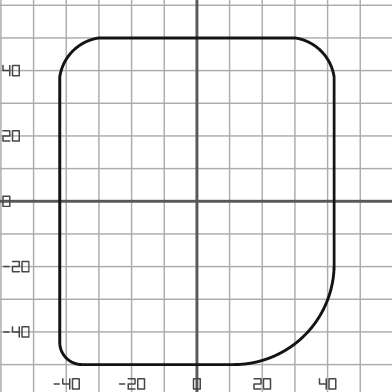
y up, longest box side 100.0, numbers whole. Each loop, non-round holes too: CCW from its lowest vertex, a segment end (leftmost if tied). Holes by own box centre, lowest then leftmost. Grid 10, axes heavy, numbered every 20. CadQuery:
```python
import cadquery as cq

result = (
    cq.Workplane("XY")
    .moveTo(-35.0, -50.0)
    .lineTo(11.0, -50.0)
    .threePointArc((33.0, -41.0), (42.0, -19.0))
    .lineTo(42.0, 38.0)
    .threePointArc((38.0, 46.0), (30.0, 50.0))
    .lineTo(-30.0, 50.0)
    .threePointArc((-38.0, 46.0), (-42.0, 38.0))
    .lineTo(-42.0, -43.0)
    .threePointArc((-40.0, -48.0), (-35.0, -50.0))
    .close()
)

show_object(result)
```